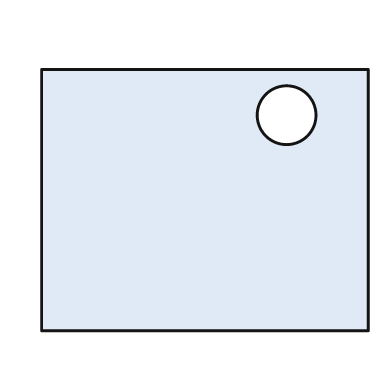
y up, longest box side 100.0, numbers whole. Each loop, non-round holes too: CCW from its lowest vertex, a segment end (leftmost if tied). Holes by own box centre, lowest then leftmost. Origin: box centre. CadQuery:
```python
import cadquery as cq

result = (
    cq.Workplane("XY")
    .moveTo(-50.0, -40.0)
    .lineTo(50.0, -40.0)
    .lineTo(50.0, 40.0)
    .lineTo(-50.0, 40.0)
    .close()
    .moveTo(25.0, 26.0)
    .circle(9.0)
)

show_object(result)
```